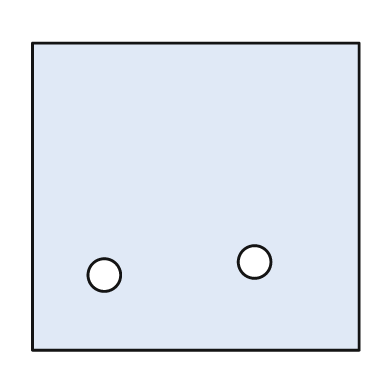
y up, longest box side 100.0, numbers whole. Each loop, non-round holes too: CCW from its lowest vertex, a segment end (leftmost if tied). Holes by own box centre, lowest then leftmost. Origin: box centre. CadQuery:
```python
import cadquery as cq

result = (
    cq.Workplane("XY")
    .moveTo(-50.0, -47.0)
    .lineTo(50.0, -47.0)
    .lineTo(50.0, 47.0)
    .lineTo(-50.0, 47.0)
    .close()
    .moveTo(-28.0, -24.0)
    .circle(5.0)
    .moveTo(18.0, -20.0)
    .circle(5.0)
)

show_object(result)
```